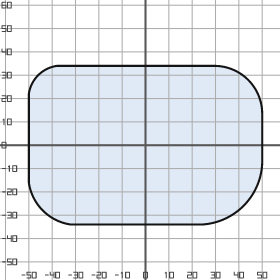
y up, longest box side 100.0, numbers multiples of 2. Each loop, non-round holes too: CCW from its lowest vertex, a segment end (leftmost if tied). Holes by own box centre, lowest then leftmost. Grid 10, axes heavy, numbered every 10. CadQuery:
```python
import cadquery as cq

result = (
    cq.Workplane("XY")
    .moveTo(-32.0, -34.0)
    .lineTo(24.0, -34.0)
    .threePointArc((42.0, -26.0), (50.0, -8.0))
    .lineTo(50.0, 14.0)
    .threePointArc((44.0, 28.0), (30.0, 34.0))
    .lineTo(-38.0, 34.0)
    .threePointArc((-46.0, 30.0), (-50.0, 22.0))
    .lineTo(-50.0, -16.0)
    .threePointArc((-44.0, -28.0), (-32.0, -34.0))
    .close()
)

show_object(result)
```